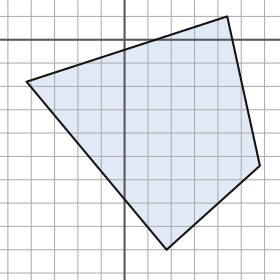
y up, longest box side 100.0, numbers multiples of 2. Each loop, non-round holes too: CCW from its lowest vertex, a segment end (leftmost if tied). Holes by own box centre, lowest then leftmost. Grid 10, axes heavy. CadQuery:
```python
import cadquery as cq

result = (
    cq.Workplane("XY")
    .moveTo(18.0, -90.0)
    .lineTo(58.0, -54.0)
    .lineTo(44.0, 10.0)
    .lineTo(-42.0, -18.0)
    .close()
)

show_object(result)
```